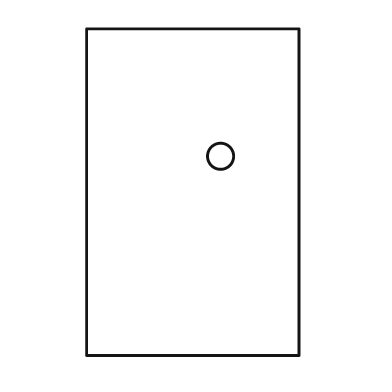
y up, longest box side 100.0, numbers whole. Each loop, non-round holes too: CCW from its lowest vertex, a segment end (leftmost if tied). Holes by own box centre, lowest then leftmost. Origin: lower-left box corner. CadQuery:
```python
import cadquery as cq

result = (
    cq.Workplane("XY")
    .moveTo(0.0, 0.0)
    .lineTo(65.0, 0.0)
    .lineTo(65.0, 100.0)
    .lineTo(0.0, 100.0)
    .close()
    .moveTo(41.0, 61.0)
    .circle(4.0)
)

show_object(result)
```